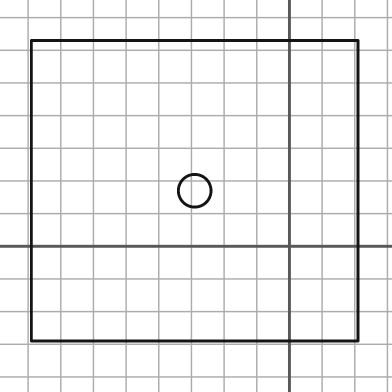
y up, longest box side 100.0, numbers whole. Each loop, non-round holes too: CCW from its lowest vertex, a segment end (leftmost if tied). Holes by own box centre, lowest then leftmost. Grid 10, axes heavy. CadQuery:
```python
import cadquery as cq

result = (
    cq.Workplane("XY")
    .moveTo(-79.0, -29.0)
    .lineTo(21.0, -29.0)
    .lineTo(21.0, 63.0)
    .lineTo(-79.0, 63.0)
    .close()
    .moveTo(-29.0, 17.0)
    .circle(5.0)
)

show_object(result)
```